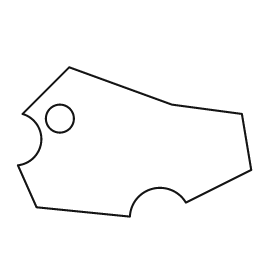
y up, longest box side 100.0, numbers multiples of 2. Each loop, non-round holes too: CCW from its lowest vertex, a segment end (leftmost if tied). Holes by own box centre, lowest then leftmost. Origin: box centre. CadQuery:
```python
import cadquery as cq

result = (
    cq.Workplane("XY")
    .moveTo(-2.0, -32.0)
    .threePointArc((8.0, -20.0), (22.0, -26.0))
    .lineTo(50.0, -12.0)
    .lineTo(46.0, 12.0)
    .lineTo(16.0, 16.0)
    .lineTo(-28.0, 32.0)
    .lineTo(-48.0, 12.0)
    .threePointArc((-40.0, 0.0), (-50.0, -10.0))
    .lineTo(-42.0, -28.0)
    .close()
    .moveTo(-32.0, 10.0)
    .circle(6.0)
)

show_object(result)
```